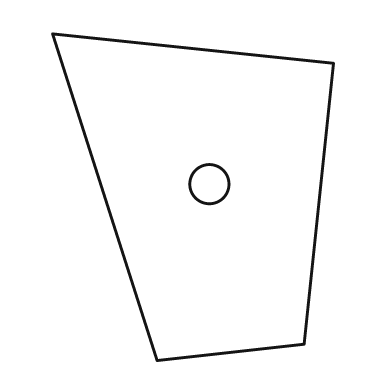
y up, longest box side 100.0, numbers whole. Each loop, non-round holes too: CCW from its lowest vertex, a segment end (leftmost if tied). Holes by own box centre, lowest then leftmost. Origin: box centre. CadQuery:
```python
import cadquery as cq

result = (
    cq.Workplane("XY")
    .moveTo(-11.0, -50.0)
    .lineTo(34.0, -45.0)
    .lineTo(43.0, 41.0)
    .lineTo(-43.0, 50.0)
    .close()
    .moveTo(5.0, 4.0)
    .circle(6.0)
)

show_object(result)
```